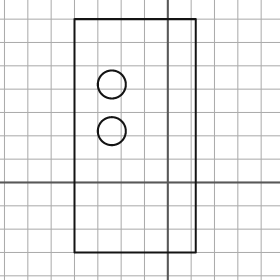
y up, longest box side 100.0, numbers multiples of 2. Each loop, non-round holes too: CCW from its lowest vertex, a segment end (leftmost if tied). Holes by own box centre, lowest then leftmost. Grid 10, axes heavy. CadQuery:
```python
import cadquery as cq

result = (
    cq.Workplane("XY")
    .moveTo(-40.0, -30.0)
    .lineTo(12.0, -30.0)
    .lineTo(12.0, 70.0)
    .lineTo(-40.0, 70.0)
    .close()
    .moveTo(-24.0, 22.0)
    .circle(6.0)
    .moveTo(-24.0, 42.0)
    .circle(6.0)
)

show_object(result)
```